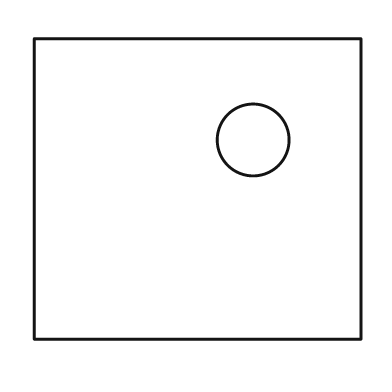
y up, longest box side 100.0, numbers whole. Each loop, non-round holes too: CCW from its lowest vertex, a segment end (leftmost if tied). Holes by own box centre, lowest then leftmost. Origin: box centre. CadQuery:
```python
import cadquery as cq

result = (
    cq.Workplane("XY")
    .moveTo(-50.0, -46.0)
    .lineTo(50.0, -46.0)
    .lineTo(50.0, 46.0)
    .lineTo(-50.0, 46.0)
    .close()
    .moveTo(17.0, 15.0)
    .circle(11.0)
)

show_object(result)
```